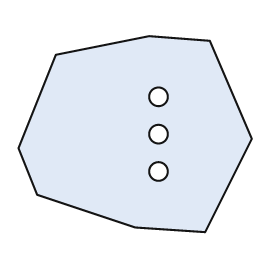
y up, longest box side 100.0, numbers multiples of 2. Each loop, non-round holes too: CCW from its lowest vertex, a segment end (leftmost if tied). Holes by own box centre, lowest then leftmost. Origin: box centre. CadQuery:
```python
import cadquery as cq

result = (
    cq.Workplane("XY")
    .moveTo(30.0, -42.0)
    .lineTo(50.0, -2.0)
    .lineTo(32.0, 40.0)
    .lineTo(6.0, 42.0)
    .lineTo(-34.0, 34.0)
    .lineTo(-50.0, -6.0)
    .lineTo(-42.0, -26.0)
    .lineTo(0.0, -40.0)
    .close()
    .moveTo(10.0, -16.0)
    .circle(4.0)
    .moveTo(10.0, 0.0)
    .circle(4.0)
    .moveTo(10.0, 16.0)
    .circle(4.0)
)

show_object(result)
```